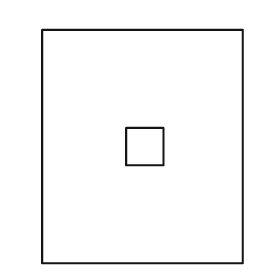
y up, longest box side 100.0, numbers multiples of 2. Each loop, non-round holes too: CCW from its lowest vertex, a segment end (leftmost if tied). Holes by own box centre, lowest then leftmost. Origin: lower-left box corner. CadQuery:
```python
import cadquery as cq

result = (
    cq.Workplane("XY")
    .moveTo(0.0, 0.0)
    .lineTo(86.0, 0.0)
    .lineTo(86.0, 100.0)
    .lineTo(0.0, 100.0)
    .close()
    .moveTo(36.0, 42.0)
    .lineTo(52.0, 42.0)
    .lineTo(52.0, 58.0)
    .lineTo(36.0, 58.0)
    .close()
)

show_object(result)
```